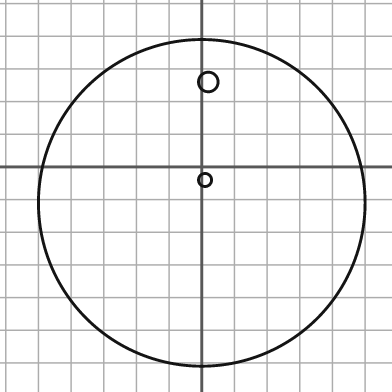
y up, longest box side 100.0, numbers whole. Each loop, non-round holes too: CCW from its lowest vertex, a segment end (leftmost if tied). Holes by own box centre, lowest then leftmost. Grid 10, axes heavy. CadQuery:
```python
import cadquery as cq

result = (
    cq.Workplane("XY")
    .moveTo(0.0, -11.0)
    .circle(50.0)
    .moveTo(1.0, -4.0)
    .circle(2.0)
    .moveTo(2.0, 26.0)
    .circle(3.0)
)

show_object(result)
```